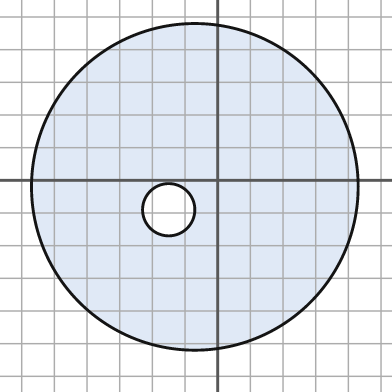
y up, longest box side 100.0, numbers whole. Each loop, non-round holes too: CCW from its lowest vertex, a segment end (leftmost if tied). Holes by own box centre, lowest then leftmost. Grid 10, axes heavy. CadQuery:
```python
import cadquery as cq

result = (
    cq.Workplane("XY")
    .moveTo(-7.0, -2.0)
    .circle(50.0)
    .moveTo(-15.0, -9.0)
    .circle(8.0)
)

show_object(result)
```